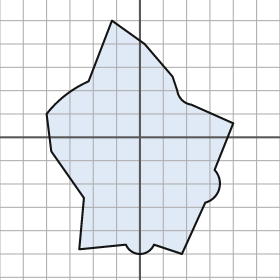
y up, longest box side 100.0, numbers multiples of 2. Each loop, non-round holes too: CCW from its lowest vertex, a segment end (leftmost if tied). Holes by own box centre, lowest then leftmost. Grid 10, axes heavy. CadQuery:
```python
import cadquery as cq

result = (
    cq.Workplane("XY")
    .moveTo(18.0, -50.0)
    .lineTo(28.0, -28.0)
    .threePointArc((34.0, -22.0), (32.0, -14.0))
    .lineTo(40.0, 6.0)
    .lineTo(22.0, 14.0)
    .threePointArc((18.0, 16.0), (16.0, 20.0))
    .lineTo(14.0, 26.0)
    .lineTo(2.0, 40.0)
    .lineTo(-12.0, 50.0)
    .lineTo(-22.0, 24.0)
    .threePointArc((-32.0, 18.0), (-40.0, 10.0))
    .lineTo(-38.0, -6.0)
    .lineTo(-24.0, -26.0)
    .lineTo(-26.0, -48.0)
    .lineTo(-6.0, -46.0)
    .threePointArc((0.0, -50.0), (6.0, -46.0))
    .close()
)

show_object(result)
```